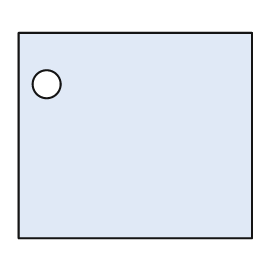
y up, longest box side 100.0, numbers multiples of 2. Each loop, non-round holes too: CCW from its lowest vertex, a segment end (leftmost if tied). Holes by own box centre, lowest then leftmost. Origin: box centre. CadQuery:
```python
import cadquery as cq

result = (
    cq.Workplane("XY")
    .moveTo(-50.0, -44.0)
    .lineTo(50.0, -44.0)
    .lineTo(50.0, 44.0)
    .lineTo(-50.0, 44.0)
    .close()
    .moveTo(-38.0, 22.0)
    .circle(6.0)
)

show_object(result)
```